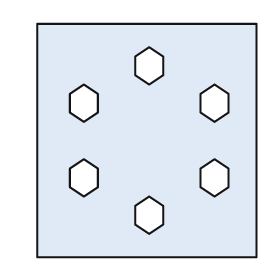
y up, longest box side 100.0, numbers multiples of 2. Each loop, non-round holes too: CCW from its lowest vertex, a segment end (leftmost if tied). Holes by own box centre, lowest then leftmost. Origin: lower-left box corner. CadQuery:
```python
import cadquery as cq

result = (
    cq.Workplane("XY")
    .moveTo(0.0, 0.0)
    .lineTo(94.0, 0.0)
    .lineTo(94.0, 100.0)
    .lineTo(0.0, 100.0)
    .close()
    .moveTo(48.0, 10.0)
    .lineTo(54.0, 14.0)
    .lineTo(54.0, 22.0)
    .lineTo(48.0, 26.0)
    .lineTo(42.0, 22.0)
    .lineTo(42.0, 14.0)
    .close()
    .moveTo(20.0, 26.0)
    .lineTo(26.0, 30.0)
    .lineTo(26.0, 38.0)
    .lineTo(20.0, 42.0)
    .lineTo(14.0, 38.0)
    .lineTo(14.0, 30.0)
    .close()
    .moveTo(76.0, 26.0)
    .lineTo(82.0, 30.0)
    .lineTo(82.0, 38.0)
    .lineTo(76.0, 42.0)
    .lineTo(70.0, 38.0)
    .lineTo(70.0, 30.0)
    .close()
    .moveTo(20.0, 58.0)
    .lineTo(26.0, 62.0)
    .lineTo(26.0, 70.0)
    .lineTo(20.0, 74.0)
    .lineTo(14.0, 70.0)
    .lineTo(14.0, 62.0)
    .close()
    .moveTo(76.0, 58.0)
    .lineTo(82.0, 62.0)
    .lineTo(82.0, 70.0)
    .lineTo(76.0, 74.0)
    .lineTo(70.0, 70.0)
    .lineTo(70.0, 62.0)
    .close()
    .moveTo(48.0, 74.0)
    .lineTo(54.0, 78.0)
    .lineTo(54.0, 86.0)
    .lineTo(48.0, 90.0)
    .lineTo(42.0, 86.0)
    .lineTo(42.0, 78.0)
    .close()
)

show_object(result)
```